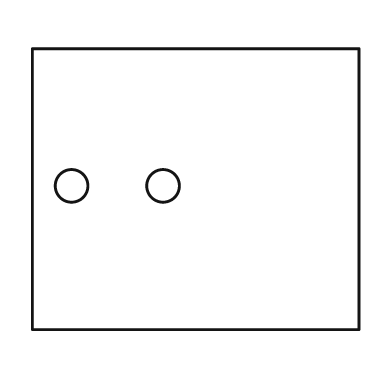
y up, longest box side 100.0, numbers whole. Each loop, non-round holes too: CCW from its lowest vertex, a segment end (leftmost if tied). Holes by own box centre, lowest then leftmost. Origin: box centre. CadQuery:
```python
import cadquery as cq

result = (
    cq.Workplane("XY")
    .moveTo(-50.0, -43.0)
    .lineTo(50.0, -43.0)
    .lineTo(50.0, 43.0)
    .lineTo(-50.0, 43.0)
    .close()
    .moveTo(-38.0, 1.0)
    .circle(5.0)
    .moveTo(-10.0, 1.0)
    .circle(5.0)
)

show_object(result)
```